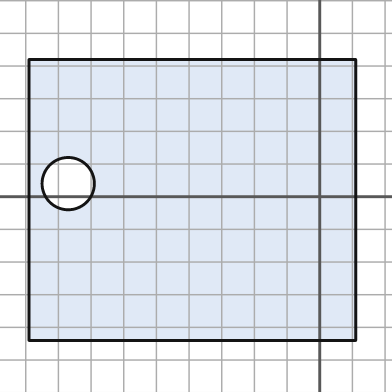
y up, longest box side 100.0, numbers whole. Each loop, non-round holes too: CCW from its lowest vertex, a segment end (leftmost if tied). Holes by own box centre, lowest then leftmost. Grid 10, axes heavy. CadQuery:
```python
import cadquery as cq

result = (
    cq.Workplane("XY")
    .moveTo(-89.0, -44.0)
    .lineTo(11.0, -44.0)
    .lineTo(11.0, 42.0)
    .lineTo(-89.0, 42.0)
    .close()
    .moveTo(-77.0, 4.0)
    .circle(8.0)
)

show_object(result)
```